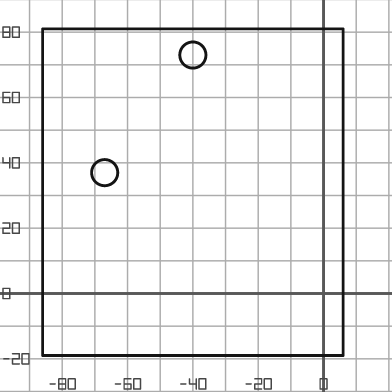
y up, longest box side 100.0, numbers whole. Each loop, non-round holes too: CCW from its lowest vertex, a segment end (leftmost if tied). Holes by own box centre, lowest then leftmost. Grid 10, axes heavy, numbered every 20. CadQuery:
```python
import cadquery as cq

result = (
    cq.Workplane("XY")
    .moveTo(-86.0, -19.0)
    .lineTo(6.0, -19.0)
    .lineTo(6.0, 81.0)
    .lineTo(-86.0, 81.0)
    .close()
    .moveTo(-67.0, 37.0)
    .circle(4.0)
    .moveTo(-40.0, 73.0)
    .circle(4.0)
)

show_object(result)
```